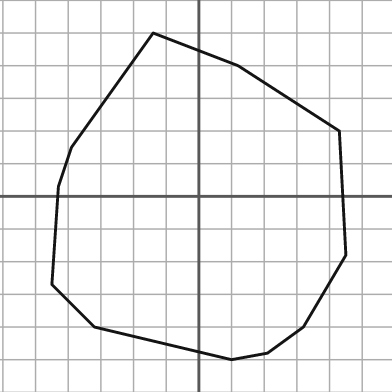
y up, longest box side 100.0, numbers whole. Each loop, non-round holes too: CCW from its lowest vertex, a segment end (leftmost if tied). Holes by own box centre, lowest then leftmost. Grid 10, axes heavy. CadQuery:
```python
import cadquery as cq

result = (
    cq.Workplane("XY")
    .moveTo(10.0, -50.0)
    .lineTo(21.0, -48.0)
    .lineTo(32.0, -40.0)
    .lineTo(45.0, -18.0)
    .lineTo(43.0, 20.0)
    .lineTo(12.0, 40.0)
    .lineTo(-14.0, 50.0)
    .lineTo(-39.0, 15.0)
    .lineTo(-43.0, 3.0)
    .lineTo(-45.0, -27.0)
    .lineTo(-32.0, -40.0)
    .close()
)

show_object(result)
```